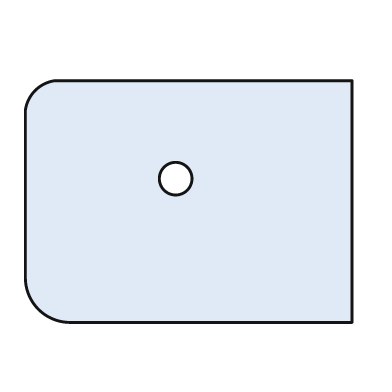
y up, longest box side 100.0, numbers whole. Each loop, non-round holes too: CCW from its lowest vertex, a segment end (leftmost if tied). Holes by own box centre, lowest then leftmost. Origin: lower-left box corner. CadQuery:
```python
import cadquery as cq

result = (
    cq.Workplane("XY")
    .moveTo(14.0, 0.0)
    .lineTo(100.0, 0.0)
    .lineTo(100.0, 74.0)
    .lineTo(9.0, 74.0)
    .threePointArc((3.0, 71.0), (0.0, 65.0))
    .lineTo(0.0, 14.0)
    .threePointArc((4.0, 4.0), (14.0, 0.0))
    .close()
    .moveTo(46.0, 44.0)
    .circle(5.0)
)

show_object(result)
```